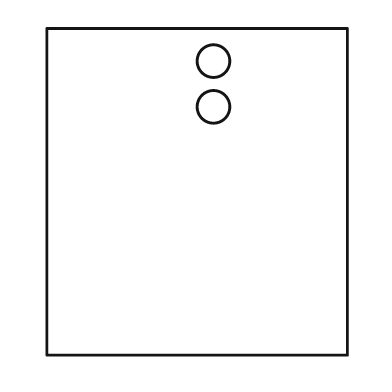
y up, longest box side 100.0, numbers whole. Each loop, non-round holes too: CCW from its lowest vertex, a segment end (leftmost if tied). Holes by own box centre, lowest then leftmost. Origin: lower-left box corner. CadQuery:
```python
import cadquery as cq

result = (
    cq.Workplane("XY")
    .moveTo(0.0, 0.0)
    .lineTo(92.0, 0.0)
    .lineTo(92.0, 100.0)
    .lineTo(0.0, 100.0)
    .close()
    .moveTo(51.0, 76.0)
    .circle(5.0)
    .moveTo(51.0, 90.0)
    .circle(5.0)
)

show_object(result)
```